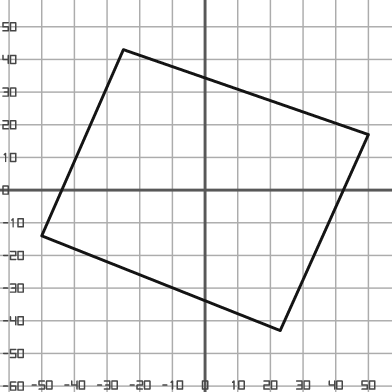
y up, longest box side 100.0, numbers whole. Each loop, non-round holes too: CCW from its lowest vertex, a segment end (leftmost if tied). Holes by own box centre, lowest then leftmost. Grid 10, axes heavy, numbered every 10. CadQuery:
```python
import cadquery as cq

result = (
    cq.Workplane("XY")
    .moveTo(23.0, -43.0)
    .lineTo(50.0, 17.0)
    .lineTo(-25.0, 43.0)
    .lineTo(-50.0, -14.0)
    .close()
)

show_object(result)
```